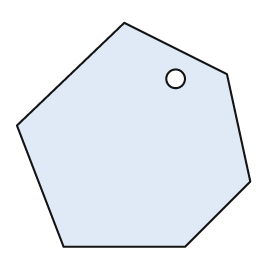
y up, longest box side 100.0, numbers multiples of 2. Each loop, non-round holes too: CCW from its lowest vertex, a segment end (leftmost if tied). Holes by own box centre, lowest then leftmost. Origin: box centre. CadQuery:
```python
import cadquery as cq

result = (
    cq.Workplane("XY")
    .moveTo(-30.0, -48.0)
    .lineTo(22.0, -48.0)
    .lineTo(50.0, -20.0)
    .lineTo(40.0, 26.0)
    .lineTo(-4.0, 48.0)
    .lineTo(-50.0, 4.0)
    .close()
    .moveTo(18.0, 24.0)
    .circle(4.0)
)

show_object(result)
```